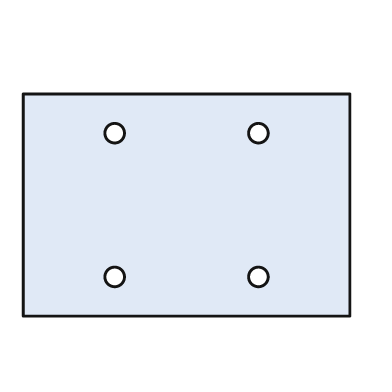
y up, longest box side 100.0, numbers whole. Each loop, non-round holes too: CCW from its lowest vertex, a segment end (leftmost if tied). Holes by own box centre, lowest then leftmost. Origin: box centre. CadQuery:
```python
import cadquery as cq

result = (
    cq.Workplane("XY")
    .moveTo(-50.0, -34.0)
    .lineTo(50.0, -34.0)
    .lineTo(50.0, 34.0)
    .lineTo(-50.0, 34.0)
    .close()
    .moveTo(-22.0, -22.0)
    .circle(3.0)
    .moveTo(22.0, -22.0)
    .circle(3.0)
    .moveTo(-22.0, 22.0)
    .circle(3.0)
    .moveTo(22.0, 22.0)
    .circle(3.0)
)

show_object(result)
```